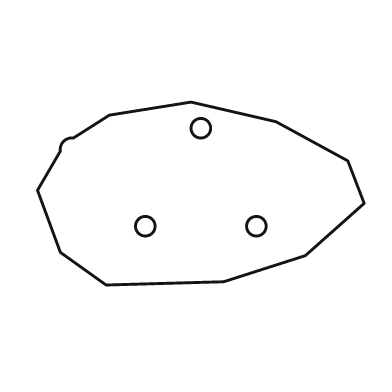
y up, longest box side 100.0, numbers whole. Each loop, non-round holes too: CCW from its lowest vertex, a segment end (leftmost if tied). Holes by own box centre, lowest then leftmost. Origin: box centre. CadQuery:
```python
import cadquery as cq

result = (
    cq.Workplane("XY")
    .moveTo(-29.0, -28.0)
    .lineTo(7.0, -27.0)
    .lineTo(32.0, -19.0)
    .lineTo(50.0, -3.0)
    .lineTo(45.0, 10.0)
    .lineTo(23.0, 22.0)
    .lineTo(-3.0, 28.0)
    .lineTo(-28.0, 24.0)
    .lineTo(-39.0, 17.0)
    .threePointArc((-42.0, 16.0), (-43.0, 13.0))
    .lineTo(-50.0, 1.0)
    .lineTo(-43.0, -18.0)
    .close()
    .moveTo(-17.0, -10.0)
    .circle(3.0)
    .moveTo(17.0, -10.0)
    .circle(3.0)
    .moveTo(0.0, 20.0)
    .circle(3.0)
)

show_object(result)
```